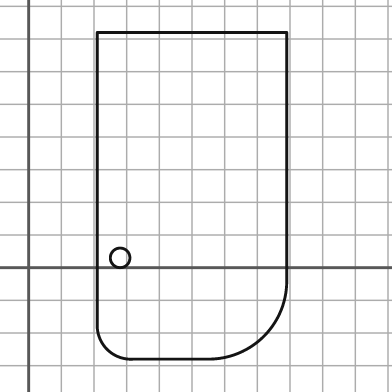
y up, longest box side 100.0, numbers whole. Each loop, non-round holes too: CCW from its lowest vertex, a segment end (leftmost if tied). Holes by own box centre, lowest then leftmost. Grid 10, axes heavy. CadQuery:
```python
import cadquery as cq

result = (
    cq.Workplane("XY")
    .moveTo(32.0, -28.0)
    .lineTo(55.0, -28.0)
    .threePointArc((72.0, -21.0), (79.0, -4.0))
    .lineTo(79.0, 72.0)
    .lineTo(21.0, 72.0)
    .lineTo(21.0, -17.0)
    .threePointArc((24.0, -25.0), (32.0, -28.0))
    .close()
    .moveTo(28.0, 3.0)
    .circle(3.0)
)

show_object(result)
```